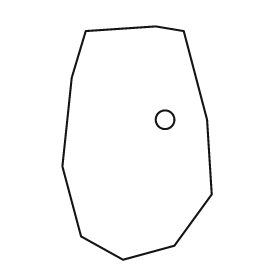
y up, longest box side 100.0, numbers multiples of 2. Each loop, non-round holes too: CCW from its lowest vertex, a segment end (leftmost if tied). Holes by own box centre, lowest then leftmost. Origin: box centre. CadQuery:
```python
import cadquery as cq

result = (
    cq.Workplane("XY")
    .moveTo(-6.0, -50.0)
    .lineTo(16.0, -44.0)
    .lineTo(32.0, -22.0)
    .lineTo(30.0, 10.0)
    .lineTo(20.0, 48.0)
    .lineTo(8.0, 50.0)
    .lineTo(-22.0, 48.0)
    .lineTo(-28.0, 28.0)
    .lineTo(-32.0, -10.0)
    .lineTo(-24.0, -40.0)
    .close()
    .moveTo(12.0, 10.0)
    .circle(4.0)
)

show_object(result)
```